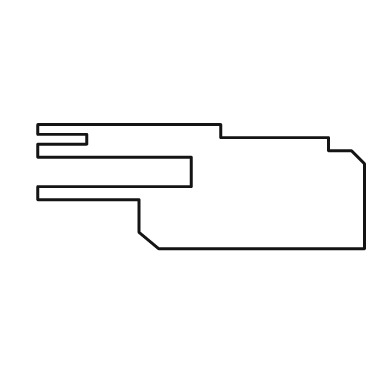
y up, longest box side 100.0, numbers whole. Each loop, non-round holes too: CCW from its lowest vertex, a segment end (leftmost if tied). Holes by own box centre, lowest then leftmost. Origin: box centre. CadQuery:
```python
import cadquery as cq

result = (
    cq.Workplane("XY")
    .moveTo(-13.0, -19.0)
    .lineTo(50.0, -19.0)
    .lineTo(50.0, 7.0)
    .lineTo(46.0, 11.0)
    .lineTo(39.0, 11.0)
    .lineTo(39.0, 15.0)
    .lineTo(6.0, 15.0)
    .lineTo(6.0, 19.0)
    .lineTo(-50.0, 19.0)
    .lineTo(-50.0, 16.0)
    .lineTo(-35.0, 16.0)
    .lineTo(-35.0, 13.0)
    .lineTo(-50.0, 13.0)
    .lineTo(-50.0, 9.0)
    .lineTo(-3.0, 9.0)
    .lineTo(-3.0, 0.0)
    .lineTo(-50.0, 0.0)
    .lineTo(-50.0, -4.0)
    .lineTo(-19.0, -4.0)
    .lineTo(-19.0, -14.0)
    .close()
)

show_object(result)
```